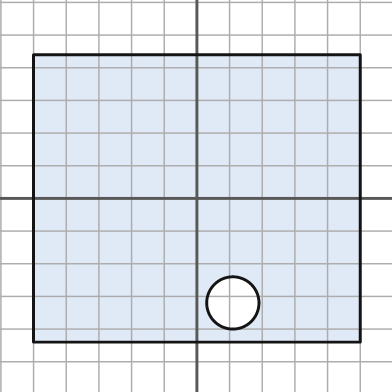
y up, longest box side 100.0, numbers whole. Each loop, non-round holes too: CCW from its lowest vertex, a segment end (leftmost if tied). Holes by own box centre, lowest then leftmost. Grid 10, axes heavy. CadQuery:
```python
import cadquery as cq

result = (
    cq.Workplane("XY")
    .moveTo(-50.0, -44.0)
    .lineTo(50.0, -44.0)
    .lineTo(50.0, 44.0)
    .lineTo(-50.0, 44.0)
    .close()
    .moveTo(11.0, -32.0)
    .circle(8.0)
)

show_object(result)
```